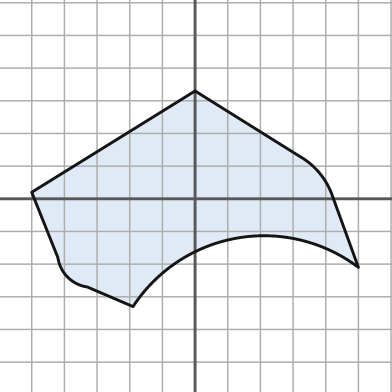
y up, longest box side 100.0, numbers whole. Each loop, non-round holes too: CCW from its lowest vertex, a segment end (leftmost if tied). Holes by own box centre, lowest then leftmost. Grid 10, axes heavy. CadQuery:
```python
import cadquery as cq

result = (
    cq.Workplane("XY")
    .moveTo(-19.0, -33.0)
    .threePointArc((13.0, -12.0), (50.0, -21.0))
    .lineTo(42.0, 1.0)
    .threePointArc((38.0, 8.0), (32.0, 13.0))
    .lineTo(0.0, 33.0)
    .lineTo(-50.0, 2.0)
    .lineTo(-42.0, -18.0)
    .threePointArc((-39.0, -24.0), (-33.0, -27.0))
    .close()
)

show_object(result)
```